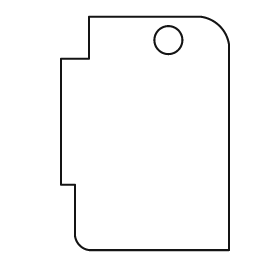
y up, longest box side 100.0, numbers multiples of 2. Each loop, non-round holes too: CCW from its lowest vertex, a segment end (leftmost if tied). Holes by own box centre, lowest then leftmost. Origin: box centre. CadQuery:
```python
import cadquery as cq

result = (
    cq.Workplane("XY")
    .moveTo(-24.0, -50.0)
    .lineTo(36.0, -50.0)
    .lineTo(36.0, 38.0)
    .threePointArc((32.0, 46.0), (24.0, 50.0))
    .lineTo(-24.0, 50.0)
    .lineTo(-24.0, 32.0)
    .lineTo(-36.0, 32.0)
    .lineTo(-36.0, -22.0)
    .lineTo(-30.0, -22.0)
    .lineTo(-30.0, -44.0)
    .threePointArc((-28.0, -48.0), (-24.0, -50.0))
    .close()
    .moveTo(10.0, 40.0)
    .circle(6.0)
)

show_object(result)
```